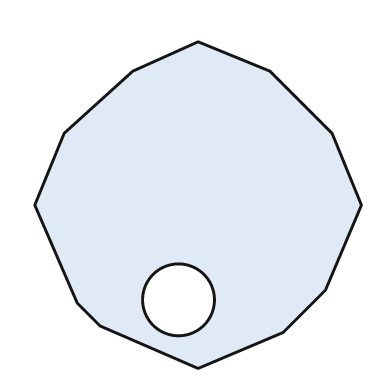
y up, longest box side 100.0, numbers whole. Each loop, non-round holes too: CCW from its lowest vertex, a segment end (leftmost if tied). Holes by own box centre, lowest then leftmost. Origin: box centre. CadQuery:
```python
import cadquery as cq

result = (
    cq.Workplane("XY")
    .moveTo(0.0, -50.0)
    .lineTo(26.0, -39.0)
    .lineTo(39.0, -26.0)
    .lineTo(50.0, 0.0)
    .lineTo(41.0, 22.0)
    .lineTo(22.0, 41.0)
    .lineTo(0.0, 50.0)
    .lineTo(-20.0, 41.0)
    .lineTo(-41.0, 22.0)
    .lineTo(-50.0, 0.0)
    .lineTo(-37.0, -30.0)
    .lineTo(-30.0, -37.0)
    .close()
    .moveTo(-6.0, -29.0)
    .circle(11.0)
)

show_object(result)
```